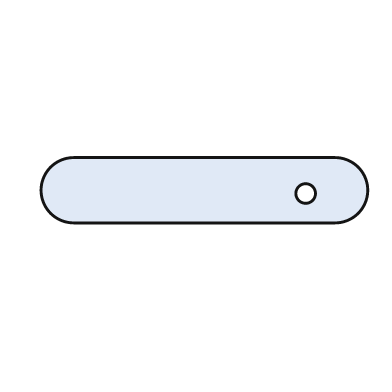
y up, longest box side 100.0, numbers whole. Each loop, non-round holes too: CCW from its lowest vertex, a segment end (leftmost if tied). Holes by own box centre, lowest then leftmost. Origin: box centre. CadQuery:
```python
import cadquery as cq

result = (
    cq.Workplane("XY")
    .moveTo(-40.0, -10.0)
    .lineTo(40.0, -10.0)
    .threePointArc((50.0, 0.0), (40.0, 10.0))
    .lineTo(-40.0, 10.0)
    .threePointArc((-50.0, 0.0), (-40.0, -10.0))
    .close()
    .moveTo(31.0, -1.0)
    .circle(3.0)
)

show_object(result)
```